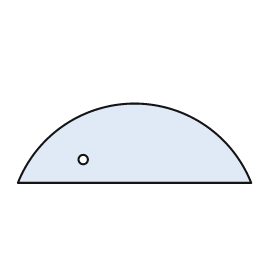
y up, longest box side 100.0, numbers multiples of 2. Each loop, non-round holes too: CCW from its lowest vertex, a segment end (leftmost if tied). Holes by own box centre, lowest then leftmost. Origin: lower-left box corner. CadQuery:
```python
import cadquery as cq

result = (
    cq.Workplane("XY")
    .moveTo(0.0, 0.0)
    .lineTo(100.0, 0.0)
    .threePointArc((50.0, 34.0), (0.0, 0.0))
    .close()
    .moveTo(28.0, 10.0)
    .circle(2.0)
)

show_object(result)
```